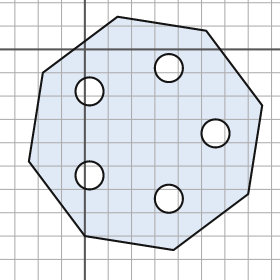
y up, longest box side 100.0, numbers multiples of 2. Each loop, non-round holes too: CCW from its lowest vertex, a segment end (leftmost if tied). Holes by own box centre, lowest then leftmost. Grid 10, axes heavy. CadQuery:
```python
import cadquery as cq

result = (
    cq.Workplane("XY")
    .moveTo(38.0, -86.0)
    .lineTo(70.0, -62.0)
    .lineTo(76.0, -24.0)
    .lineTo(52.0, 8.0)
    .lineTo(14.0, 14.0)
    .lineTo(-18.0, -10.0)
    .lineTo(-24.0, -48.0)
    .lineTo(0.0, -80.0)
    .close()
    .moveTo(36.0, -64.0)
    .circle(6.0)
    .moveTo(2.0, -54.0)
    .circle(6.0)
    .moveTo(56.0, -36.0)
    .circle(6.0)
    .moveTo(2.0, -18.0)
    .circle(6.0)
    .moveTo(36.0, -8.0)
    .circle(6.0)
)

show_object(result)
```